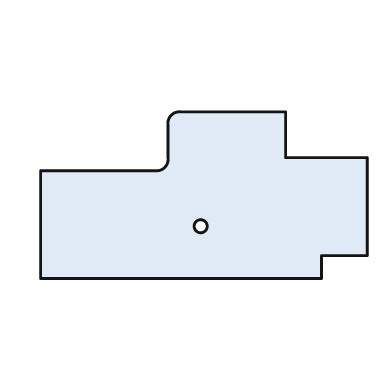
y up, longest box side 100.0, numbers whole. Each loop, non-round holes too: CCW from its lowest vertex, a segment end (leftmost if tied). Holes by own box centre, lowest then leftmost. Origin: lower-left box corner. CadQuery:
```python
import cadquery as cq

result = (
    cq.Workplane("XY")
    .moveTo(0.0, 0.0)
    .lineTo(86.0, 0.0)
    .lineTo(86.0, 7.0)
    .lineTo(100.0, 7.0)
    .lineTo(100.0, 37.0)
    .lineTo(75.0, 37.0)
    .lineTo(75.0, 51.0)
    .lineTo(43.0, 51.0)
    .threePointArc((40.0, 50.0), (39.0, 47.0))
    .lineTo(39.0, 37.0)
    .threePointArc((38.0, 34.0), (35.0, 33.0))
    .lineTo(0.0, 33.0)
    .close()
    .moveTo(49.0, 16.0)
    .circle(2.0)
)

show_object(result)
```